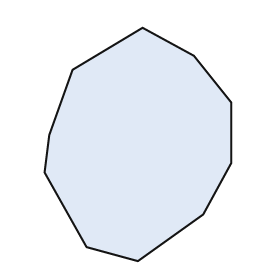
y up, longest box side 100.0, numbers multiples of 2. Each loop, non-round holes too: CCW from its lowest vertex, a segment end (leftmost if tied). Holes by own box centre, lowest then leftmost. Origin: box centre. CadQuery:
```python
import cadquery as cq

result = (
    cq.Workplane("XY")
    .moveTo(0.0, -50.0)
    .lineTo(28.0, -30.0)
    .lineTo(40.0, -8.0)
    .lineTo(40.0, 18.0)
    .lineTo(24.0, 38.0)
    .lineTo(2.0, 50.0)
    .lineTo(-28.0, 32.0)
    .lineTo(-38.0, 4.0)
    .lineTo(-40.0, -12.0)
    .lineTo(-22.0, -44.0)
    .close()
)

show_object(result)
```